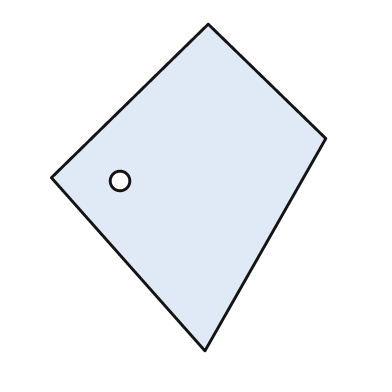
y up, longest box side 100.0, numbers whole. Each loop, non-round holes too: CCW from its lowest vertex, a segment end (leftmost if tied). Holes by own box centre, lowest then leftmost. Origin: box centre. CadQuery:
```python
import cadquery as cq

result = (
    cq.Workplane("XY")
    .moveTo(5.0, -50.0)
    .lineTo(42.0, 15.0)
    .lineTo(6.0, 50.0)
    .lineTo(-42.0, 3.0)
    .close()
    .moveTo(-21.0, 2.0)
    .circle(3.0)
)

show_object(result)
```